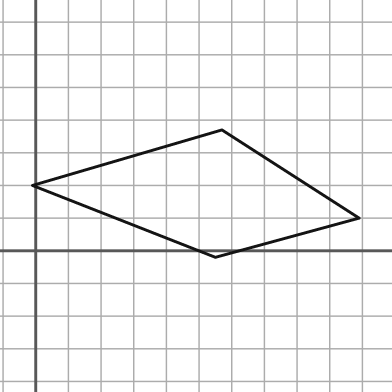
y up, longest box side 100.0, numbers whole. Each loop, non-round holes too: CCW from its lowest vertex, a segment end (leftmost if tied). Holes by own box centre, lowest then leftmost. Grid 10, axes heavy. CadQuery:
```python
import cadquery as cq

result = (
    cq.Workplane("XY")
    .moveTo(55.0, -2.0)
    .lineTo(99.0, 10.0)
    .lineTo(57.0, 37.0)
    .lineTo(-1.0, 20.0)
    .close()
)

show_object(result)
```